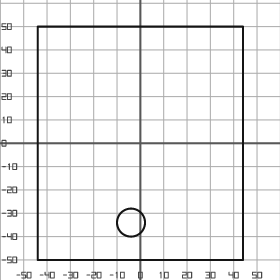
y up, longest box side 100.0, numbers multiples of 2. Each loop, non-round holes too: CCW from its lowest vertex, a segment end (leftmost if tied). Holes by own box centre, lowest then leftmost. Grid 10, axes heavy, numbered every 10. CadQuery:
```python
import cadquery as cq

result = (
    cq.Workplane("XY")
    .moveTo(-44.0, -50.0)
    .lineTo(44.0, -50.0)
    .lineTo(44.0, 50.0)
    .lineTo(-44.0, 50.0)
    .close()
    .moveTo(-4.0, -34.0)
    .circle(6.0)
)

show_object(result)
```